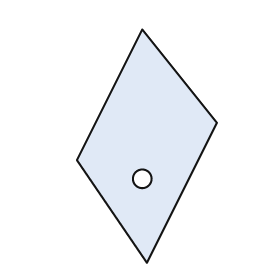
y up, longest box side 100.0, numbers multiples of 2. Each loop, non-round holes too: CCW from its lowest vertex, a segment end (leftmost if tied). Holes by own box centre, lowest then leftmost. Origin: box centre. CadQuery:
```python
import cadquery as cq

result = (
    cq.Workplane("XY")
    .moveTo(0.0, -50.0)
    .lineTo(30.0, 10.0)
    .lineTo(-2.0, 50.0)
    .lineTo(-30.0, -6.0)
    .close()
    .moveTo(-2.0, -14.0)
    .circle(4.0)
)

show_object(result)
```